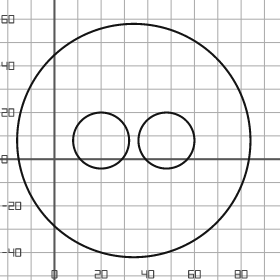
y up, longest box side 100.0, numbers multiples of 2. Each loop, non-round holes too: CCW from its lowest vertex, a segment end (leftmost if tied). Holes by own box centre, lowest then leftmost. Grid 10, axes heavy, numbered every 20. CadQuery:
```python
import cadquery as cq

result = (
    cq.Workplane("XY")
    .moveTo(34.0, 8.0)
    .circle(50.0)
    .moveTo(20.0, 8.0)
    .circle(12.0)
    .moveTo(48.0, 8.0)
    .circle(12.0)
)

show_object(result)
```